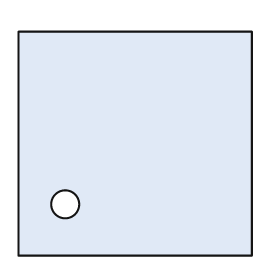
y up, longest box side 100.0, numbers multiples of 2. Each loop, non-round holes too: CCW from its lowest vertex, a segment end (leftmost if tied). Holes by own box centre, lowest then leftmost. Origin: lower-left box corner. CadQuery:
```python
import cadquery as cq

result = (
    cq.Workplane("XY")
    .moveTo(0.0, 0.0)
    .lineTo(100.0, 0.0)
    .lineTo(100.0, 96.0)
    .lineTo(0.0, 96.0)
    .close()
    .moveTo(20.0, 22.0)
    .circle(6.0)
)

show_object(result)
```